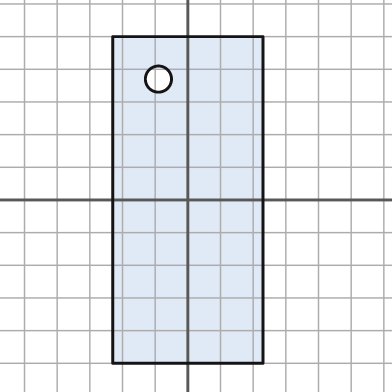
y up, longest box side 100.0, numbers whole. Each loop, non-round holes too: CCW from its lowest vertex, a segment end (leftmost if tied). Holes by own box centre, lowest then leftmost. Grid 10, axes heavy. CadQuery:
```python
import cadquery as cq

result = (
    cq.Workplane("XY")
    .moveTo(-23.0, -50.0)
    .lineTo(23.0, -50.0)
    .lineTo(23.0, 50.0)
    .lineTo(-23.0, 50.0)
    .close()
    .moveTo(-9.0, 37.0)
    .circle(4.0)
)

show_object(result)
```